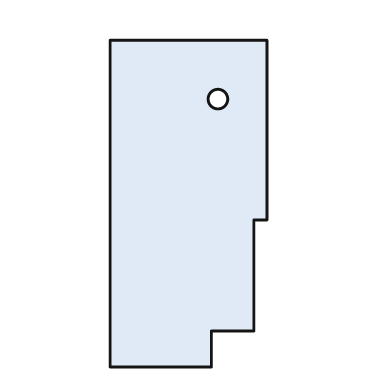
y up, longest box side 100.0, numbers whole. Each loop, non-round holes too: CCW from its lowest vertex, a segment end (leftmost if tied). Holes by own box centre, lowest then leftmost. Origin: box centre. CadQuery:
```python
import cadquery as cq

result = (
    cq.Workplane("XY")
    .moveTo(-24.0, -50.0)
    .lineTo(7.0, -50.0)
    .lineTo(7.0, -39.0)
    .lineTo(20.0, -39.0)
    .lineTo(20.0, -5.0)
    .lineTo(24.0, -5.0)
    .lineTo(24.0, 50.0)
    .lineTo(-24.0, 50.0)
    .close()
    .moveTo(9.0, 32.0)
    .circle(3.0)
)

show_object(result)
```